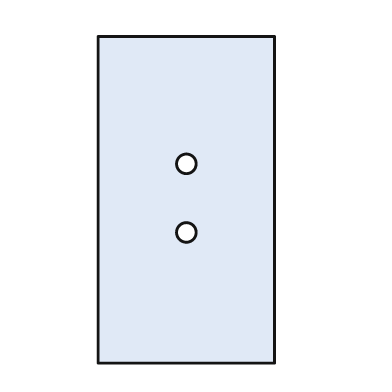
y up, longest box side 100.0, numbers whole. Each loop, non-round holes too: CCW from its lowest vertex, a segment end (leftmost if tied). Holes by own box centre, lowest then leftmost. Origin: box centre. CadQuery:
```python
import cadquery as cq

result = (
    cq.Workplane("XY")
    .moveTo(-27.0, -50.0)
    .lineTo(27.0, -50.0)
    .lineTo(27.0, 50.0)
    .lineTo(-27.0, 50.0)
    .close()
    .moveTo(0.0, -10.0)
    .circle(3.0)
    .moveTo(0.0, 11.0)
    .circle(3.0)
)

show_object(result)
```